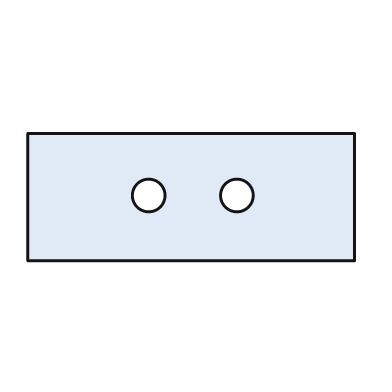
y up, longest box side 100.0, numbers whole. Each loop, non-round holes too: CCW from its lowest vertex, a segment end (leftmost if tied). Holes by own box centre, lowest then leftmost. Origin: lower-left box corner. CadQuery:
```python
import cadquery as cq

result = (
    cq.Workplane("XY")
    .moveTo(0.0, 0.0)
    .lineTo(100.0, 0.0)
    .lineTo(100.0, 39.0)
    .lineTo(0.0, 39.0)
    .close()
    .moveTo(37.0, 20.0)
    .circle(5.0)
    .moveTo(64.0, 20.0)
    .circle(5.0)
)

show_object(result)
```